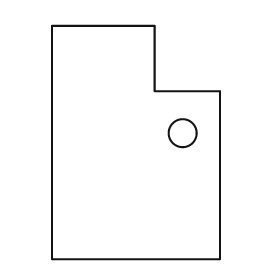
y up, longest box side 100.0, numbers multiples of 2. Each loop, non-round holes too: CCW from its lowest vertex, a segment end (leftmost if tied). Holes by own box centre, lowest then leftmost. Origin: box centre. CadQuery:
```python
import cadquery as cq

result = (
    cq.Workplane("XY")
    .moveTo(-36.0, -50.0)
    .lineTo(36.0, -50.0)
    .lineTo(36.0, 22.0)
    .lineTo(8.0, 22.0)
    .lineTo(8.0, 50.0)
    .lineTo(-36.0, 50.0)
    .close()
    .moveTo(20.0, 4.0)
    .circle(6.0)
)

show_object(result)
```